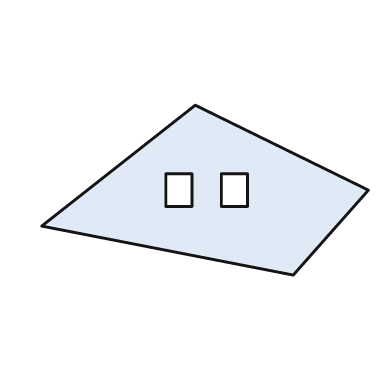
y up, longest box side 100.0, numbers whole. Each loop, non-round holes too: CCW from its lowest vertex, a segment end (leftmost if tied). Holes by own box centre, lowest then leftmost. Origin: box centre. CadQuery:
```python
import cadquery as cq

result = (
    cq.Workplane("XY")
    .moveTo(27.0, -26.0)
    .lineTo(50.0, 0.0)
    .lineTo(-3.0, 26.0)
    .lineTo(-50.0, -11.0)
    .close()
    .moveTo(-12.0, -5.0)
    .lineTo(-4.0, -5.0)
    .lineTo(-4.0, 5.0)
    .lineTo(-12.0, 5.0)
    .close()
    .moveTo(5.0, -5.0)
    .lineTo(13.0, -5.0)
    .lineTo(13.0, 5.0)
    .lineTo(5.0, 5.0)
    .close()
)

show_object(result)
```